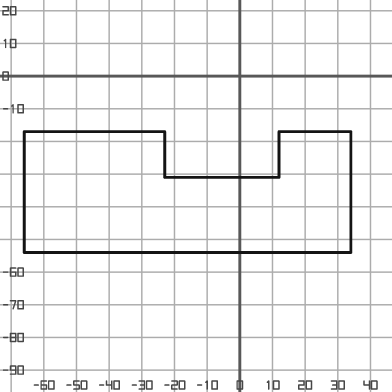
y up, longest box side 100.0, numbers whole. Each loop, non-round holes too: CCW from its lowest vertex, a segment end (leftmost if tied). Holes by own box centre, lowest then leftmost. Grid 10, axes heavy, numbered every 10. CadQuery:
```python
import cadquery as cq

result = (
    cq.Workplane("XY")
    .moveTo(-66.0, -54.0)
    .lineTo(34.0, -54.0)
    .lineTo(34.0, -17.0)
    .lineTo(12.0, -17.0)
    .lineTo(12.0, -31.0)
    .lineTo(-23.0, -31.0)
    .lineTo(-23.0, -17.0)
    .lineTo(-66.0, -17.0)
    .close()
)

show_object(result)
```